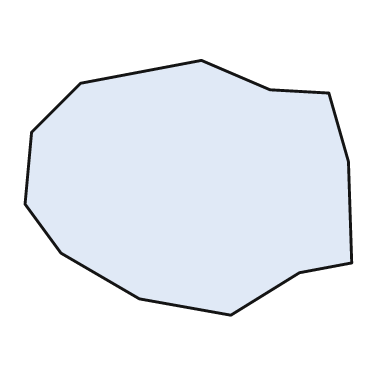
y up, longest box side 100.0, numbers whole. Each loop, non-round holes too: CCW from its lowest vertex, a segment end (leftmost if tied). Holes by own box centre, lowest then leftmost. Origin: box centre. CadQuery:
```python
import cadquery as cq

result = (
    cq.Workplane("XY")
    .moveTo(13.0, -39.0)
    .lineTo(34.0, -26.0)
    .lineTo(50.0, -23.0)
    .lineTo(49.0, 8.0)
    .lineTo(43.0, 29.0)
    .lineTo(25.0, 30.0)
    .lineTo(4.0, 39.0)
    .lineTo(-33.0, 32.0)
    .lineTo(-48.0, 17.0)
    .lineTo(-50.0, -5.0)
    .lineTo(-39.0, -20.0)
    .lineTo(-15.0, -34.0)
    .close()
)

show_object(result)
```